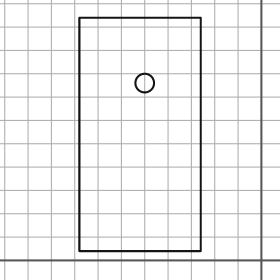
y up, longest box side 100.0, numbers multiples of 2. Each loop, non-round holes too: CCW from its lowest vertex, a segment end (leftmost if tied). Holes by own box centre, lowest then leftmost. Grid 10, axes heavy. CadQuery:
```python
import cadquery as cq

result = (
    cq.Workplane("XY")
    .moveTo(-78.0, 4.0)
    .lineTo(-26.0, 4.0)
    .lineTo(-26.0, 104.0)
    .lineTo(-78.0, 104.0)
    .close()
    .moveTo(-50.0, 76.0)
    .circle(4.0)
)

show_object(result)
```